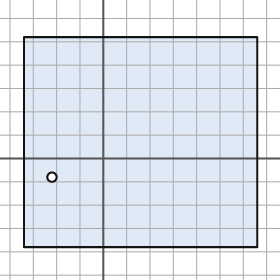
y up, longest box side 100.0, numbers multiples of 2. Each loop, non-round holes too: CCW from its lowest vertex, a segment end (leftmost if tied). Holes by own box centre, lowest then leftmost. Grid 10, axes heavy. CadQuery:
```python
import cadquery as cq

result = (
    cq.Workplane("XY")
    .moveTo(-34.0, -38.0)
    .lineTo(66.0, -38.0)
    .lineTo(66.0, 52.0)
    .lineTo(-34.0, 52.0)
    .close()
    .moveTo(-22.0, -8.0)
    .circle(2.0)
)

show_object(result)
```